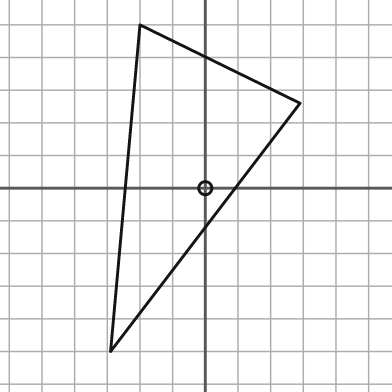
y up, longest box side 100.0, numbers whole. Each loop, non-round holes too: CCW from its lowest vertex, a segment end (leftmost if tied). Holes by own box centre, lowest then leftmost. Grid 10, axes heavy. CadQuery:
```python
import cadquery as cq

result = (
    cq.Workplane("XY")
    .moveTo(-29.0, -50.0)
    .lineTo(29.0, 26.0)
    .lineTo(-20.0, 50.0)
    .close()
    .moveTo(0.0, 0.0)
    .circle(2.0)
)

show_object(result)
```